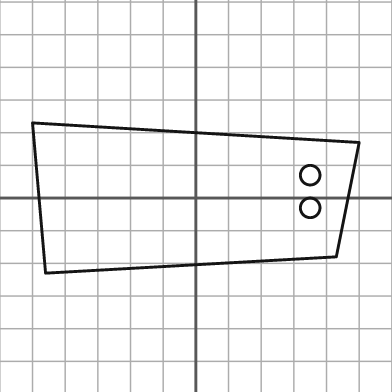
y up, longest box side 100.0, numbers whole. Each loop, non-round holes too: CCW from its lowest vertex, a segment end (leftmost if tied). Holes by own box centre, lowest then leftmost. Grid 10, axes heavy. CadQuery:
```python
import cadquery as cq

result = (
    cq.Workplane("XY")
    .moveTo(-46.0, -23.0)
    .lineTo(43.0, -18.0)
    .lineTo(50.0, 17.0)
    .lineTo(-50.0, 23.0)
    .close()
    .moveTo(35.0, -3.0)
    .circle(3.0)
    .moveTo(35.0, 7.0)
    .circle(3.0)
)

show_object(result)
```